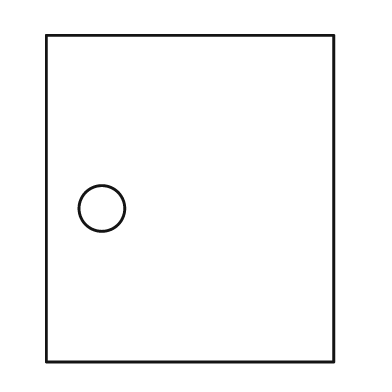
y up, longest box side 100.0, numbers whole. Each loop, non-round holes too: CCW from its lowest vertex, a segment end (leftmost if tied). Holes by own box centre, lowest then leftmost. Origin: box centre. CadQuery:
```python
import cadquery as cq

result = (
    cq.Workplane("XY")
    .moveTo(-44.0, -50.0)
    .lineTo(44.0, -50.0)
    .lineTo(44.0, 50.0)
    .lineTo(-44.0, 50.0)
    .close()
    .moveTo(-27.0, -3.0)
    .circle(7.0)
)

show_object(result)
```